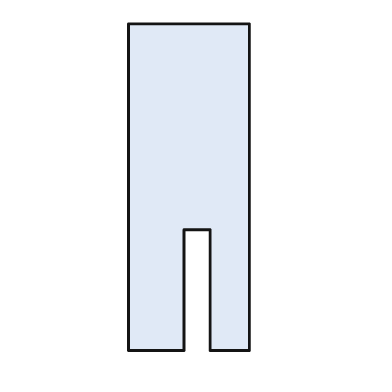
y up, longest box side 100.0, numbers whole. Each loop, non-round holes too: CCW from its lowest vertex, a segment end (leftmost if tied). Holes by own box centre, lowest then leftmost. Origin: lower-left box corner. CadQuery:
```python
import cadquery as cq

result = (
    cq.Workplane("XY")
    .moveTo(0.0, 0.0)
    .lineTo(17.0, 0.0)
    .lineTo(17.0, 37.0)
    .lineTo(25.0, 37.0)
    .lineTo(25.0, 0.0)
    .lineTo(37.0, 0.0)
    .lineTo(37.0, 100.0)
    .lineTo(0.0, 100.0)
    .close()
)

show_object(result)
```